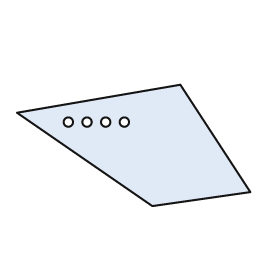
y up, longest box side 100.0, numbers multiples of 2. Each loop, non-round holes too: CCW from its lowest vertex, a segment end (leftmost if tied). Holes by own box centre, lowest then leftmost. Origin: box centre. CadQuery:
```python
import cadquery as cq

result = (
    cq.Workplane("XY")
    .moveTo(8.0, -26.0)
    .lineTo(50.0, -20.0)
    .lineTo(20.0, 26.0)
    .lineTo(-50.0, 14.0)
    .close()
    .moveTo(-28.0, 10.0)
    .circle(2.0)
    .moveTo(-20.0, 10.0)
    .circle(2.0)
    .moveTo(-12.0, 10.0)
    .circle(2.0)
    .moveTo(-4.0, 10.0)
    .circle(2.0)
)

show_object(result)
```